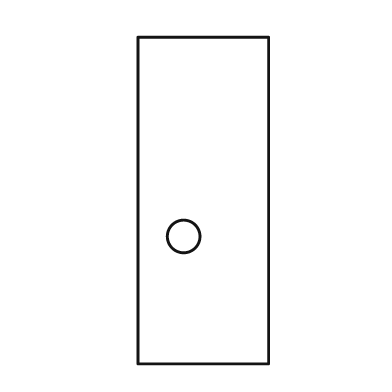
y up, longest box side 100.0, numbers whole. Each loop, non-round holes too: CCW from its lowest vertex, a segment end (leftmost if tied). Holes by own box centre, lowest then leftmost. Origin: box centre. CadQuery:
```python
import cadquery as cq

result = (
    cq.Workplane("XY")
    .moveTo(-20.0, -50.0)
    .lineTo(20.0, -50.0)
    .lineTo(20.0, 50.0)
    .lineTo(-20.0, 50.0)
    .close()
    .moveTo(-6.0, -11.0)
    .circle(5.0)
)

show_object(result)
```